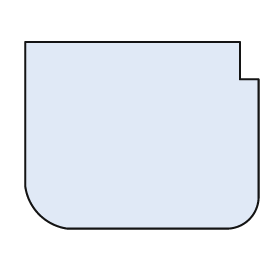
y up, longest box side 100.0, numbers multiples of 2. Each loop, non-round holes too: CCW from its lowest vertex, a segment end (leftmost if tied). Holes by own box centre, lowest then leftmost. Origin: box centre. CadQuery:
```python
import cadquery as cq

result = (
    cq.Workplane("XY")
    .moveTo(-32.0, -40.0)
    .lineTo(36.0, -40.0)
    .threePointArc((46.0, -36.0), (50.0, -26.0))
    .lineTo(50.0, 24.0)
    .lineTo(42.0, 24.0)
    .lineTo(42.0, 40.0)
    .lineTo(-50.0, 40.0)
    .lineTo(-50.0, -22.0)
    .threePointArc((-44.0, -34.0), (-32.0, -40.0))
    .close()
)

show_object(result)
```